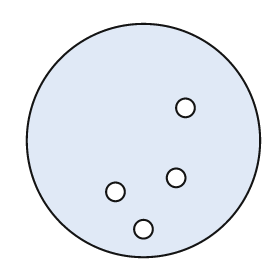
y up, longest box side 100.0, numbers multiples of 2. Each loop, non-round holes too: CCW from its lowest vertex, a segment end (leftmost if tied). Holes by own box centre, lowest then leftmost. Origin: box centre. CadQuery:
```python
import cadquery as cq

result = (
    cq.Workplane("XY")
    .moveTo(0.0, 0.0)
    .circle(50.0)
    .moveTo(0.0, -38.0)
    .circle(4.0)
    .moveTo(-12.0, -22.0)
    .circle(4.0)
    .moveTo(14.0, -16.0)
    .circle(4.0)
    .moveTo(18.0, 14.0)
    .circle(4.0)
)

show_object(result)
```